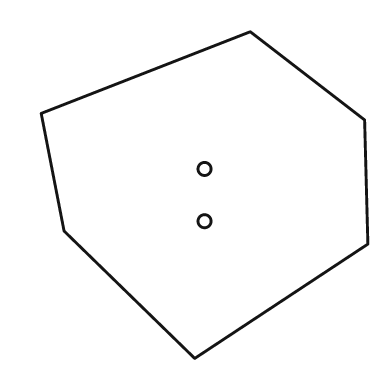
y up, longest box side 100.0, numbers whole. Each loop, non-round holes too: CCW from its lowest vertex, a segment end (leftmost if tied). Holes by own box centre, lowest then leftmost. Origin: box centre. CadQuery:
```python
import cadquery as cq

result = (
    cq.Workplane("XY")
    .moveTo(-3.0, -50.0)
    .lineTo(50.0, -15.0)
    .lineTo(49.0, 23.0)
    .lineTo(14.0, 50.0)
    .lineTo(-50.0, 25.0)
    .lineTo(-43.0, -11.0)
    .close()
    .moveTo(0.0, -8.0)
    .circle(2.0)
    .moveTo(0.0, 8.0)
    .circle(2.0)
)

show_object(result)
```